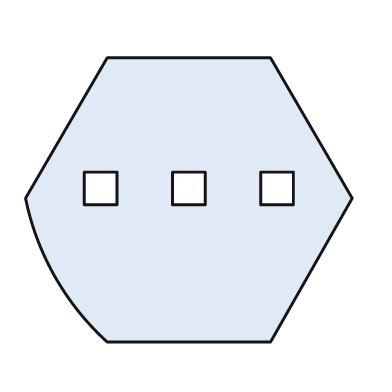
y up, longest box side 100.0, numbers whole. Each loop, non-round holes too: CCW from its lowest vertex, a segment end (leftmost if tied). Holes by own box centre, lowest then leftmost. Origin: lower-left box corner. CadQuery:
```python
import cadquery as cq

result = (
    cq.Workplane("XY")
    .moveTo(25.0, 0.0)
    .lineTo(75.0, 0.0)
    .lineTo(100.0, 44.0)
    .lineTo(75.0, 87.0)
    .lineTo(25.0, 87.0)
    .lineTo(0.0, 44.0)
    .threePointArc((9.0, 20.0), (25.0, 0.0))
    .close()
    .moveTo(18.0, 42.0)
    .lineTo(28.0, 42.0)
    .lineTo(28.0, 52.0)
    .lineTo(18.0, 52.0)
    .close()
    .moveTo(45.0, 42.0)
    .lineTo(55.0, 42.0)
    .lineTo(55.0, 52.0)
    .lineTo(45.0, 52.0)
    .close()
    .moveTo(72.0, 42.0)
    .lineTo(82.0, 42.0)
    .lineTo(82.0, 52.0)
    .lineTo(72.0, 52.0)
    .close()
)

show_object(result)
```